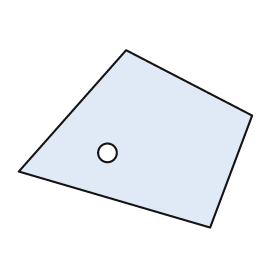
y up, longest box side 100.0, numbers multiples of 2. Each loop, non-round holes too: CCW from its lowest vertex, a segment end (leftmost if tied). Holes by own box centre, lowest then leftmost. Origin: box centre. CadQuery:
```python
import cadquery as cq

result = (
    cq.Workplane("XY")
    .moveTo(32.0, -38.0)
    .lineTo(50.0, 10.0)
    .lineTo(-4.0, 38.0)
    .lineTo(-50.0, -14.0)
    .close()
    .moveTo(-12.0, -6.0)
    .circle(4.0)
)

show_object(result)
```